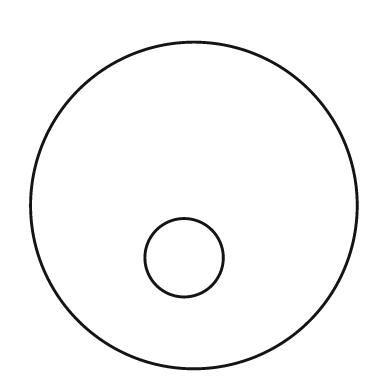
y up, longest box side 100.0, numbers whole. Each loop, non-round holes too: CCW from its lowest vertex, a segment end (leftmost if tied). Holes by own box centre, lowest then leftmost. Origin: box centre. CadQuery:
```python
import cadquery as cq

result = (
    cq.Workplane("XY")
    .moveTo(0.0, 0.0)
    .circle(50.0)
    .moveTo(-3.0, -16.0)
    .circle(12.0)
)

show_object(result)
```